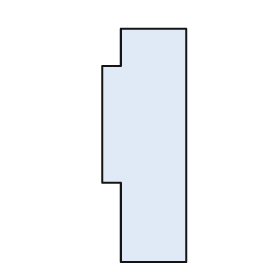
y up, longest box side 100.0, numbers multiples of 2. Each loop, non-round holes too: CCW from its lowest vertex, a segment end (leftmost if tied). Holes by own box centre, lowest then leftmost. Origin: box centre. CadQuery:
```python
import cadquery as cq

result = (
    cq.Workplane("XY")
    .moveTo(-10.0, -50.0)
    .lineTo(18.0, -50.0)
    .lineTo(18.0, 50.0)
    .lineTo(-10.0, 50.0)
    .lineTo(-10.0, 34.0)
    .lineTo(-18.0, 34.0)
    .lineTo(-18.0, -16.0)
    .lineTo(-10.0, -16.0)
    .close()
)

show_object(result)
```